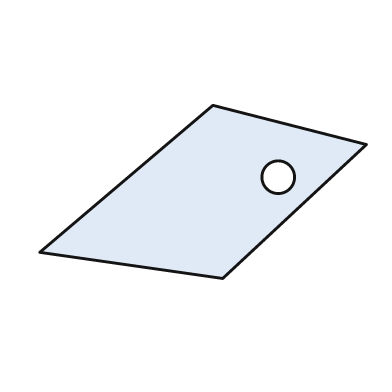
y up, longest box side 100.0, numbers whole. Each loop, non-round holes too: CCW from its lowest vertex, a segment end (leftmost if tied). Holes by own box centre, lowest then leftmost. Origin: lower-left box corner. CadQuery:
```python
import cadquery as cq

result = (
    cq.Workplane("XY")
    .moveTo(56.0, 0.0)
    .lineTo(100.0, 41.0)
    .lineTo(53.0, 53.0)
    .lineTo(0.0, 8.0)
    .close()
    .moveTo(73.0, 31.0)
    .circle(5.0)
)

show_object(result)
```